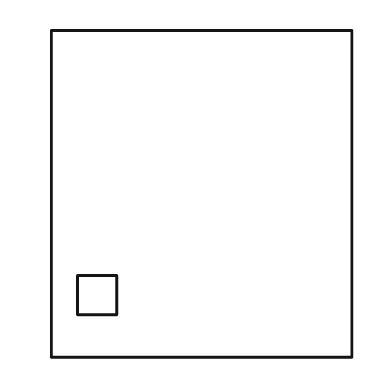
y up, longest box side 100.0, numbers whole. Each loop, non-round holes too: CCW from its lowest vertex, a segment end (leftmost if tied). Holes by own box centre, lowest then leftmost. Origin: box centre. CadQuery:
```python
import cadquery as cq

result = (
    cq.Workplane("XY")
    .moveTo(-46.0, -50.0)
    .lineTo(46.0, -50.0)
    .lineTo(46.0, 50.0)
    .lineTo(-46.0, 50.0)
    .close()
    .moveTo(-38.0, -37.0)
    .lineTo(-26.0, -37.0)
    .lineTo(-26.0, -25.0)
    .lineTo(-38.0, -25.0)
    .close()
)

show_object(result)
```